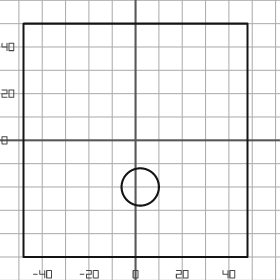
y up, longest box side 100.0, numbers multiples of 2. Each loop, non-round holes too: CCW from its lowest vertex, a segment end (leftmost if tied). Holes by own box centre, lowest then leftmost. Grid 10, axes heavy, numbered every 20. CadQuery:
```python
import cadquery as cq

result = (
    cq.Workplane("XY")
    .moveTo(-48.0, -50.0)
    .lineTo(48.0, -50.0)
    .lineTo(48.0, 50.0)
    .lineTo(-48.0, 50.0)
    .close()
    .moveTo(2.0, -20.0)
    .circle(8.0)
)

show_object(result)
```